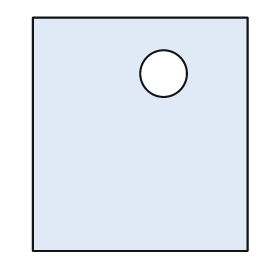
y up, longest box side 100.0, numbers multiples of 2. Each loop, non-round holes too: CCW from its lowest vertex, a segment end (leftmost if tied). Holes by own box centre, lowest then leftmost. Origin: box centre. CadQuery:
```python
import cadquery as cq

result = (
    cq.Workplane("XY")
    .moveTo(-46.0, -50.0)
    .lineTo(46.0, -50.0)
    .lineTo(46.0, 50.0)
    .lineTo(-46.0, 50.0)
    .close()
    .moveTo(10.0, 26.0)
    .circle(10.0)
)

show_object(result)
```